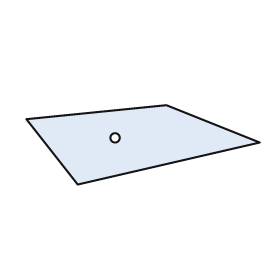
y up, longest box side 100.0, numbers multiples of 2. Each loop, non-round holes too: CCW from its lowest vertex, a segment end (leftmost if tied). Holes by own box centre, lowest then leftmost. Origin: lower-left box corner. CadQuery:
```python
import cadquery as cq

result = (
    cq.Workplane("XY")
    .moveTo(22.0, 0.0)
    .lineTo(100.0, 18.0)
    .lineTo(60.0, 34.0)
    .lineTo(0.0, 28.0)
    .close()
    .moveTo(38.0, 20.0)
    .circle(2.0)
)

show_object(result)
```